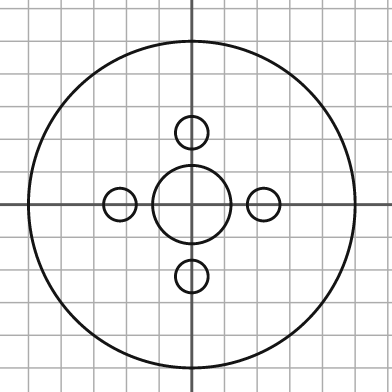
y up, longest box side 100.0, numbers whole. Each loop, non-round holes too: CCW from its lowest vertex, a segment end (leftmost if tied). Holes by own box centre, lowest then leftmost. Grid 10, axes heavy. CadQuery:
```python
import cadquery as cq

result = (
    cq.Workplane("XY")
    .moveTo(0.0, 0.0)
    .circle(50.0)
    .moveTo(0.0, -22.0)
    .circle(5.0)
    .moveTo(-22.0, 0.0)
    .circle(5.0)
    .moveTo(0.0, 0.0)
    .circle(12.0)
    .moveTo(22.0, 0.0)
    .circle(5.0)
    .moveTo(0.0, 22.0)
    .circle(5.0)
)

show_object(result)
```